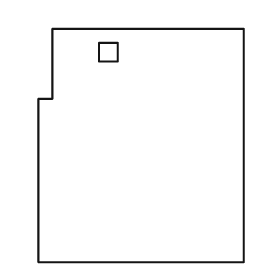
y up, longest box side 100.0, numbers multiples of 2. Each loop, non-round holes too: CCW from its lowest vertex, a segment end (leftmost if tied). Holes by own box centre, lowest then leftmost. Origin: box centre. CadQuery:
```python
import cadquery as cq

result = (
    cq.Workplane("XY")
    .moveTo(-44.0, -50.0)
    .lineTo(44.0, -50.0)
    .lineTo(44.0, 50.0)
    .lineTo(-38.0, 50.0)
    .lineTo(-38.0, 20.0)
    .lineTo(-44.0, 20.0)
    .close()
    .moveTo(-18.0, 36.0)
    .lineTo(-10.0, 36.0)
    .lineTo(-10.0, 44.0)
    .lineTo(-18.0, 44.0)
    .close()
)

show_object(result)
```